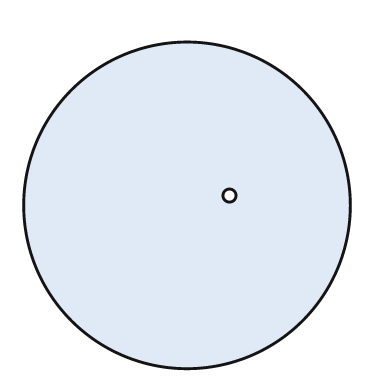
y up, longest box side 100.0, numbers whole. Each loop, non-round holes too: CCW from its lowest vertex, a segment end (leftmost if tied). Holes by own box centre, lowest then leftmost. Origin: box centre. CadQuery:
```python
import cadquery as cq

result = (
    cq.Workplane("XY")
    .moveTo(0.0, 0.0)
    .circle(50.0)
    .moveTo(13.0, 3.0)
    .circle(2.0)
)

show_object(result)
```